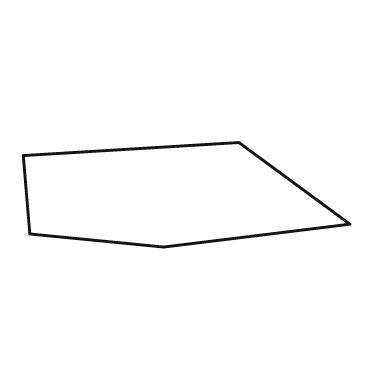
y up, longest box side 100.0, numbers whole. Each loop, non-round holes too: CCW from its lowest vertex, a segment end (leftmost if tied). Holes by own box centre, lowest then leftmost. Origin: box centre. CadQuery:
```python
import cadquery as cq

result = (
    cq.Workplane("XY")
    .moveTo(-7.0, -16.0)
    .lineTo(50.0, -9.0)
    .lineTo(16.0, 16.0)
    .lineTo(-50.0, 12.0)
    .lineTo(-48.0, -12.0)
    .close()
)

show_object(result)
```